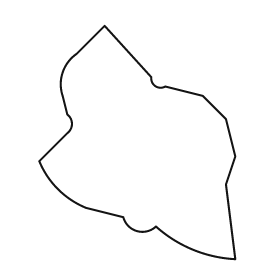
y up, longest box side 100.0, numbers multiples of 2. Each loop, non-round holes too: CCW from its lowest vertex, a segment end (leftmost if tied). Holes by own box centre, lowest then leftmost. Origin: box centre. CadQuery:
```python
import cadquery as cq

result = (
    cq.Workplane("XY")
    .moveTo(42.0, -50.0)
    .lineTo(38.0, -18.0)
    .lineTo(42.0, -6.0)
    .lineTo(38.0, 10.0)
    .lineTo(28.0, 20.0)
    .lineTo(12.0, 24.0)
    .threePointArc((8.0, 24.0), (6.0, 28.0))
    .lineTo(-14.0, 50.0)
    .lineTo(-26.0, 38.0)
    .threePointArc((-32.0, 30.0), (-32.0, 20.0))
    .lineTo(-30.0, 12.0)
    .threePointArc((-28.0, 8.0), (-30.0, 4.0))
    .lineTo(-42.0, -8.0)
    .threePointArc((-34.0, -20.0), (-22.0, -28.0))
    .lineTo(-6.0, -32.0)
    .threePointArc((0.0, -38.0), (8.0, -36.0))
    .threePointArc((24.0, -46.0), (42.0, -50.0))
    .close()
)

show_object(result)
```